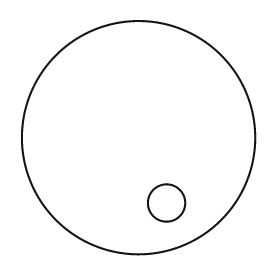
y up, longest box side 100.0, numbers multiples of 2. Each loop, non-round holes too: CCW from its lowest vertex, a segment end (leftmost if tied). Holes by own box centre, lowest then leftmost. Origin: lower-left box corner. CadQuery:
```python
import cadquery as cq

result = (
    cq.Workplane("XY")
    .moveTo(50.0, 50.0)
    .circle(50.0)
    .moveTo(62.0, 22.0)
    .circle(8.0)
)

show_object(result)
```